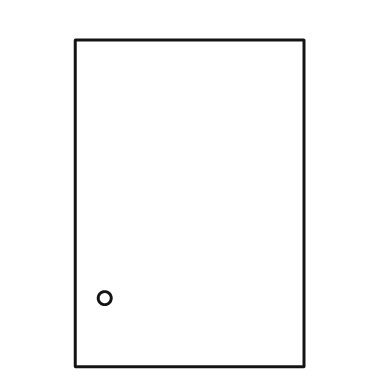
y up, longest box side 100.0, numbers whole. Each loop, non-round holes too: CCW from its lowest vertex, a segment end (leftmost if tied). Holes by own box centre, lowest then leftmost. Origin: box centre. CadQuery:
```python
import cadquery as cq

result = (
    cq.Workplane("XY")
    .moveTo(-35.0, -50.0)
    .lineTo(35.0, -50.0)
    .lineTo(35.0, 50.0)
    .lineTo(-35.0, 50.0)
    .close()
    .moveTo(-26.0, -29.0)
    .circle(2.0)
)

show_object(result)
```